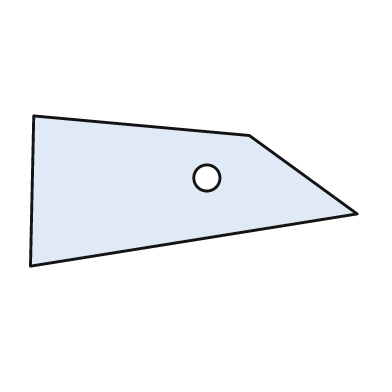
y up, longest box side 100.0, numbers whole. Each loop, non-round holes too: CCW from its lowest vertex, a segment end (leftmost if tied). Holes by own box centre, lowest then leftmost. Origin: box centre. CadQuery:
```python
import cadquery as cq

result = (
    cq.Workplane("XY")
    .moveTo(-50.0, -23.0)
    .lineTo(50.0, -7.0)
    .lineTo(17.0, 17.0)
    .lineTo(-49.0, 23.0)
    .close()
    .moveTo(4.0, 4.0)
    .circle(4.0)
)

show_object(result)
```